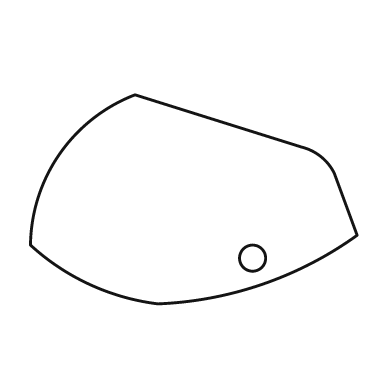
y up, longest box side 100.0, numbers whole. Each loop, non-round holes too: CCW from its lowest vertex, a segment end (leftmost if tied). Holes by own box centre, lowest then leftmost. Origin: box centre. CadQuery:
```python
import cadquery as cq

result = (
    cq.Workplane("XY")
    .moveTo(-11.0, -32.0)
    .threePointArc((21.0, -26.0), (50.0, -11.0))
    .lineTo(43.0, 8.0)
    .threePointArc((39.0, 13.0), (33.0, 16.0))
    .lineTo(-18.0, 32.0)
    .threePointArc((-41.0, 14.0), (-50.0, -14.0))
    .threePointArc((-32.0, -26.0), (-11.0, -32.0))
    .close()
    .moveTo(18.0, -18.0)
    .circle(4.0)
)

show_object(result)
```